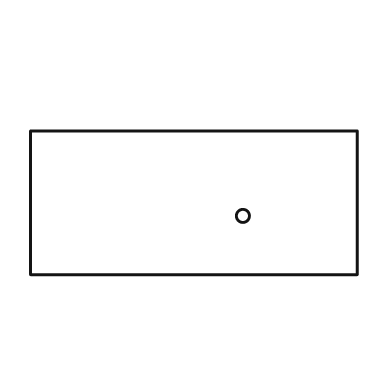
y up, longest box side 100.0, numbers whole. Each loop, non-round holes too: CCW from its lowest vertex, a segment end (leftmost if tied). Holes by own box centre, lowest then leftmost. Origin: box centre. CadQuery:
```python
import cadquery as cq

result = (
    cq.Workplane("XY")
    .moveTo(-50.0, -22.0)
    .lineTo(50.0, -22.0)
    .lineTo(50.0, 22.0)
    .lineTo(-50.0, 22.0)
    .close()
    .moveTo(15.0, -4.0)
    .circle(2.0)
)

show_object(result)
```